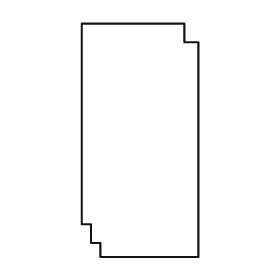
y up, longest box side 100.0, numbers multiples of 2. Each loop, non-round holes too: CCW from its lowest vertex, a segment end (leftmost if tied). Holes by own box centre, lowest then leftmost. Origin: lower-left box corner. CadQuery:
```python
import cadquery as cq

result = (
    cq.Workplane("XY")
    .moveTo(8.0, 0.0)
    .lineTo(50.0, 0.0)
    .lineTo(50.0, 92.0)
    .lineTo(44.0, 92.0)
    .lineTo(44.0, 100.0)
    .lineTo(0.0, 100.0)
    .lineTo(0.0, 14.0)
    .lineTo(4.0, 14.0)
    .lineTo(4.0, 6.0)
    .lineTo(8.0, 6.0)
    .close()
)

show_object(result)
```